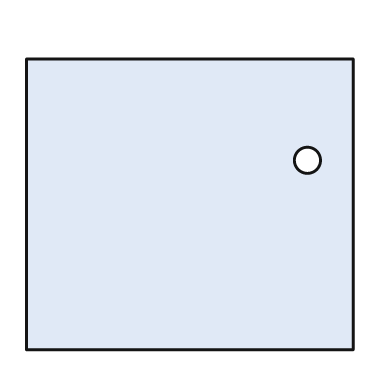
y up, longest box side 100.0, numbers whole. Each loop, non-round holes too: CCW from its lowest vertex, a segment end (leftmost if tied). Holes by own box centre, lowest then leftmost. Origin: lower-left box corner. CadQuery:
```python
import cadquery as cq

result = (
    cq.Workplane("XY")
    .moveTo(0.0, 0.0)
    .lineTo(100.0, 0.0)
    .lineTo(100.0, 89.0)
    .lineTo(0.0, 89.0)
    .close()
    .moveTo(86.0, 58.0)
    .circle(4.0)
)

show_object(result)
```